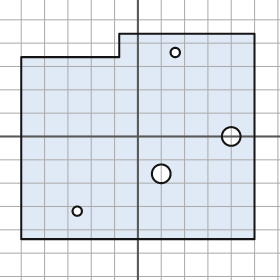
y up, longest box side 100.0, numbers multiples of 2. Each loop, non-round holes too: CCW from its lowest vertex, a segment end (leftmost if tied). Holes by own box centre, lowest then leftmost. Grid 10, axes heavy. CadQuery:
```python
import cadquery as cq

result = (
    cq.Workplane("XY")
    .moveTo(-50.0, -44.0)
    .lineTo(50.0, -44.0)
    .lineTo(50.0, 44.0)
    .lineTo(-8.0, 44.0)
    .lineTo(-8.0, 34.0)
    .lineTo(-50.0, 34.0)
    .close()
    .moveTo(-26.0, -32.0)
    .circle(2.0)
    .moveTo(10.0, -16.0)
    .circle(4.0)
    .moveTo(40.0, 0.0)
    .circle(4.0)
    .moveTo(16.0, 36.0)
    .circle(2.0)
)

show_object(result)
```